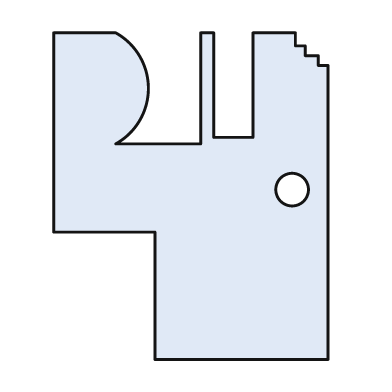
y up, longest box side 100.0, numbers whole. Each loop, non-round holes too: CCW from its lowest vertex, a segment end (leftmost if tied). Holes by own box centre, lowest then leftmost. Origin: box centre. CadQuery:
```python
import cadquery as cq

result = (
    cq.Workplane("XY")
    .moveTo(-11.0, -50.0)
    .lineTo(42.0, -50.0)
    .lineTo(42.0, 40.0)
    .lineTo(39.0, 40.0)
    .lineTo(39.0, 43.0)
    .lineTo(35.0, 43.0)
    .lineTo(35.0, 46.0)
    .lineTo(32.0, 46.0)
    .lineTo(32.0, 50.0)
    .lineTo(19.0, 50.0)
    .lineTo(19.0, 18.0)
    .lineTo(7.0, 18.0)
    .lineTo(7.0, 50.0)
    .lineTo(3.0, 50.0)
    .lineTo(3.0, 16.0)
    .lineTo(-23.0, 16.0)
    .threePointArc((-13.0, 33.0), (-23.0, 50.0))
    .lineTo(-42.0, 50.0)
    .lineTo(-42.0, -11.0)
    .lineTo(-11.0, -11.0)
    .close()
    .moveTo(31.0, 2.0)
    .circle(5.0)
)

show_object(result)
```